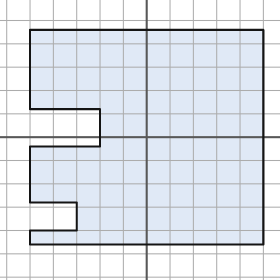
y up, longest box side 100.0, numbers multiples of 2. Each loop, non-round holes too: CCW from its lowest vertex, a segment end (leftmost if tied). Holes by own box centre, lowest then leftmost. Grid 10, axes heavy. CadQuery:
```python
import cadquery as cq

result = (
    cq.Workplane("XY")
    .moveTo(-50.0, -46.0)
    .lineTo(50.0, -46.0)
    .lineTo(50.0, 46.0)
    .lineTo(-50.0, 46.0)
    .lineTo(-50.0, 12.0)
    .lineTo(-20.0, 12.0)
    .lineTo(-20.0, -4.0)
    .lineTo(-50.0, -4.0)
    .lineTo(-50.0, -28.0)
    .lineTo(-30.0, -28.0)
    .lineTo(-30.0, -40.0)
    .lineTo(-50.0, -40.0)
    .close()
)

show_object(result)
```